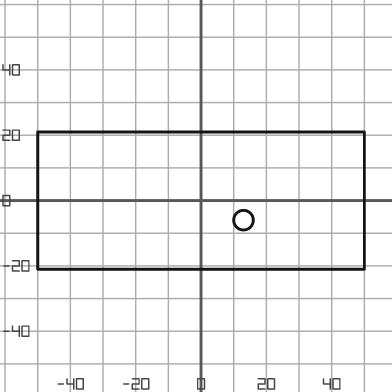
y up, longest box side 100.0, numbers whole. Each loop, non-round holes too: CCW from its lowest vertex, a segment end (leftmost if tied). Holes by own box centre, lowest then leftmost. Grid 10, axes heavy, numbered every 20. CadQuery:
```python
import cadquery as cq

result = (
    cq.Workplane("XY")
    .moveTo(-50.0, -21.0)
    .lineTo(50.0, -21.0)
    .lineTo(50.0, 21.0)
    .lineTo(-50.0, 21.0)
    .close()
    .moveTo(13.0, -6.0)
    .circle(3.0)
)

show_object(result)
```